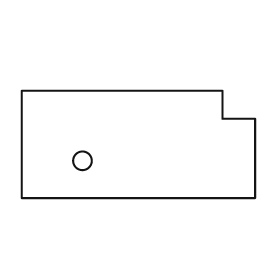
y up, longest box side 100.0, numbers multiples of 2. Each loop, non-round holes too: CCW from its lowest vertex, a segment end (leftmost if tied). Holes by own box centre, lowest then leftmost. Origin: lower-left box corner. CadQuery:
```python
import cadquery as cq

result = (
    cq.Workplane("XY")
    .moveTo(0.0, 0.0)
    .lineTo(100.0, 0.0)
    .lineTo(100.0, 34.0)
    .lineTo(86.0, 34.0)
    .lineTo(86.0, 46.0)
    .lineTo(0.0, 46.0)
    .close()
    .moveTo(26.0, 16.0)
    .circle(4.0)
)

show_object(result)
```